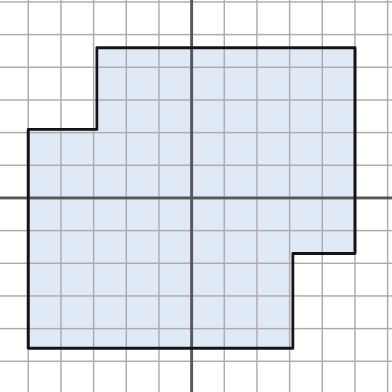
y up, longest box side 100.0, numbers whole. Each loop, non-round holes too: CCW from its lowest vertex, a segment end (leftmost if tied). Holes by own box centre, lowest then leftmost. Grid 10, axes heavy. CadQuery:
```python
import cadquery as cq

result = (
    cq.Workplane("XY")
    .moveTo(-50.0, -46.0)
    .lineTo(31.0, -46.0)
    .lineTo(31.0, -17.0)
    .lineTo(50.0, -17.0)
    .lineTo(50.0, 46.0)
    .lineTo(-29.0, 46.0)
    .lineTo(-29.0, 21.0)
    .lineTo(-50.0, 21.0)
    .close()
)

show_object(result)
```